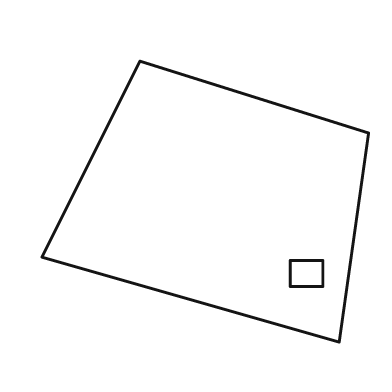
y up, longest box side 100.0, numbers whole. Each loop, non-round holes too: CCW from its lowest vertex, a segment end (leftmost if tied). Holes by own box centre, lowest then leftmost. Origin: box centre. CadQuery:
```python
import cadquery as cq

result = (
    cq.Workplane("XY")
    .moveTo(41.0, -43.0)
    .lineTo(50.0, 21.0)
    .lineTo(-20.0, 43.0)
    .lineTo(-50.0, -17.0)
    .close()
    .moveTo(26.0, -26.0)
    .lineTo(36.0, -26.0)
    .lineTo(36.0, -18.0)
    .lineTo(26.0, -18.0)
    .close()
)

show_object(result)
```